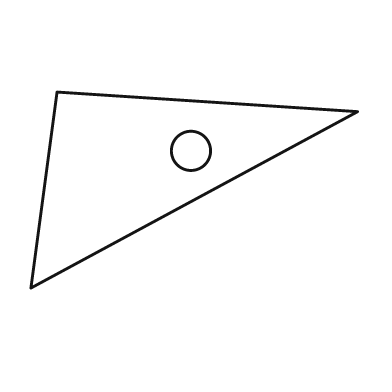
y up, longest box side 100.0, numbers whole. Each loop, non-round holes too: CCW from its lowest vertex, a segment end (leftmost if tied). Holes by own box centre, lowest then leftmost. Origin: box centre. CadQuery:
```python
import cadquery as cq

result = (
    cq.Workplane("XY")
    .moveTo(-50.0, -30.0)
    .lineTo(50.0, 24.0)
    .lineTo(-42.0, 30.0)
    .close()
    .moveTo(-1.0, 12.0)
    .circle(6.0)
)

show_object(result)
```